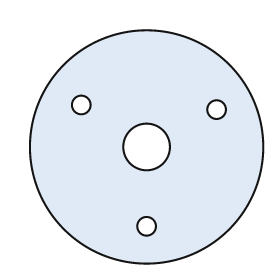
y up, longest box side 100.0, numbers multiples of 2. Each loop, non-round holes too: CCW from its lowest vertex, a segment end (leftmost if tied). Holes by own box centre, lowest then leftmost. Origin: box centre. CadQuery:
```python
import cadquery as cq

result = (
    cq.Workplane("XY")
    .moveTo(0.0, 0.0)
    .circle(50.0)
    .moveTo(0.0, -34.0)
    .circle(4.0)
    .moveTo(0.0, 0.0)
    .circle(10.0)
    .moveTo(30.0, 16.0)
    .circle(4.0)
    .moveTo(-28.0, 18.0)
    .circle(4.0)
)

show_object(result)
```